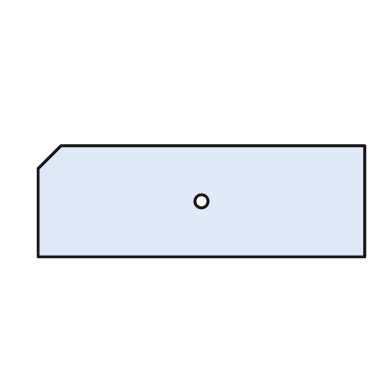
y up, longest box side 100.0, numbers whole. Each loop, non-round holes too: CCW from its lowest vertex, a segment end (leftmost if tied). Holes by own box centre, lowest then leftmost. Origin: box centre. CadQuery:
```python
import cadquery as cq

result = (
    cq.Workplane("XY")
    .moveTo(-50.0, -17.0)
    .lineTo(50.0, -17.0)
    .lineTo(50.0, 17.0)
    .lineTo(-43.0, 17.0)
    .lineTo(-50.0, 10.0)
    .close()
    .moveTo(0.0, 0.0)
    .circle(2.0)
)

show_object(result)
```